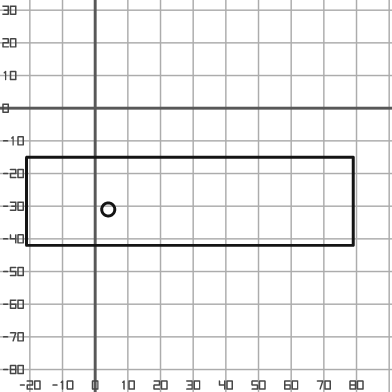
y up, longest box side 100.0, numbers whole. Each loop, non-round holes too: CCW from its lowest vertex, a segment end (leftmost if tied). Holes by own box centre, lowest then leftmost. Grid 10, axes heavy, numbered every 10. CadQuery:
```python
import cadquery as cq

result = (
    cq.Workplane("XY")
    .moveTo(-21.0, -42.0)
    .lineTo(79.0, -42.0)
    .lineTo(79.0, -15.0)
    .lineTo(-21.0, -15.0)
    .close()
    .moveTo(4.0, -31.0)
    .circle(2.0)
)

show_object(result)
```